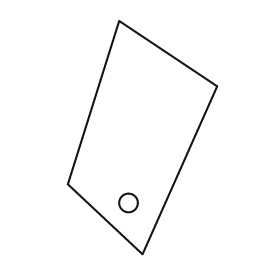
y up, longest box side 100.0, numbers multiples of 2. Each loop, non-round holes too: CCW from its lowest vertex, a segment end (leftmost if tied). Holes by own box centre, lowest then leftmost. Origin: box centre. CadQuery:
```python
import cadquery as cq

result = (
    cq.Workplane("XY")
    .moveTo(0.0, -50.0)
    .lineTo(32.0, 22.0)
    .lineTo(-10.0, 50.0)
    .lineTo(-32.0, -20.0)
    .close()
    .moveTo(-6.0, -28.0)
    .circle(4.0)
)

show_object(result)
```